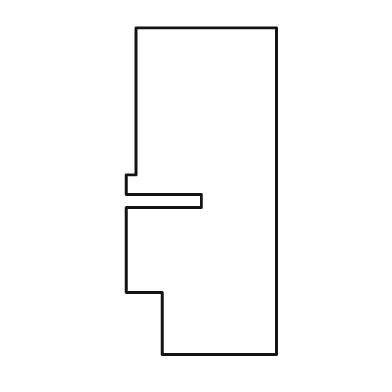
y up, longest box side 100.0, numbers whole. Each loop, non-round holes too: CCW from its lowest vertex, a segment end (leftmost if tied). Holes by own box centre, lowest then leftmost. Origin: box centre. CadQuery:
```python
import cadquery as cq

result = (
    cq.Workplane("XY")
    .moveTo(-12.0, -50.0)
    .lineTo(23.0, -50.0)
    .lineTo(23.0, 50.0)
    .lineTo(-20.0, 50.0)
    .lineTo(-20.0, 5.0)
    .lineTo(-23.0, 5.0)
    .lineTo(-23.0, -1.0)
    .lineTo(0.0, -1.0)
    .lineTo(0.0, -5.0)
    .lineTo(-23.0, -5.0)
    .lineTo(-23.0, -31.0)
    .lineTo(-12.0, -31.0)
    .close()
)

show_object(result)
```